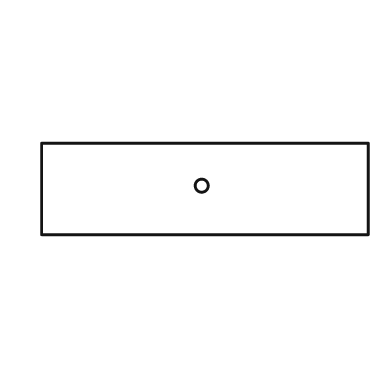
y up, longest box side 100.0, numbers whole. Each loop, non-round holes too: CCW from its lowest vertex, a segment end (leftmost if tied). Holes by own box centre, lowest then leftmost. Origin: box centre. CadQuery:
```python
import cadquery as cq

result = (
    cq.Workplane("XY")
    .moveTo(-50.0, -14.0)
    .lineTo(50.0, -14.0)
    .lineTo(50.0, 14.0)
    .lineTo(-50.0, 14.0)
    .close()
    .moveTo(-1.0, 1.0)
    .circle(2.0)
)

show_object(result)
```